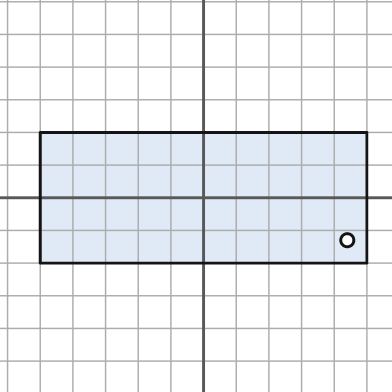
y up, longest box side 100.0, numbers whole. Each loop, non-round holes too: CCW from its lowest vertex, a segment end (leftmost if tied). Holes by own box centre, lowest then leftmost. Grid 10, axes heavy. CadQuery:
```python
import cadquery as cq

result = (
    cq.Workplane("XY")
    .moveTo(-50.0, -20.0)
    .lineTo(50.0, -20.0)
    .lineTo(50.0, 20.0)
    .lineTo(-50.0, 20.0)
    .close()
    .moveTo(44.0, -13.0)
    .circle(2.0)
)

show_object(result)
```